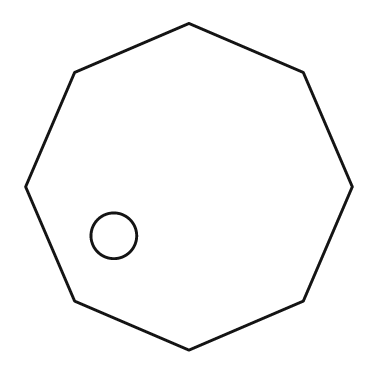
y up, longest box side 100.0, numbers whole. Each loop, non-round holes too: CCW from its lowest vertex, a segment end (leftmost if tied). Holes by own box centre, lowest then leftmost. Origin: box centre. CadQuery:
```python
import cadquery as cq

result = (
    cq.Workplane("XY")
    .moveTo(0.0, -50.0)
    .lineTo(35.0, -35.0)
    .lineTo(50.0, 0.0)
    .lineTo(35.0, 35.0)
    .lineTo(0.0, 50.0)
    .lineTo(-35.0, 35.0)
    .lineTo(-50.0, 0.0)
    .lineTo(-35.0, -35.0)
    .close()
    .moveTo(-23.0, -15.0)
    .circle(7.0)
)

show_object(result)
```